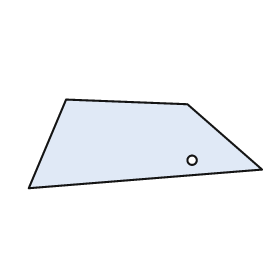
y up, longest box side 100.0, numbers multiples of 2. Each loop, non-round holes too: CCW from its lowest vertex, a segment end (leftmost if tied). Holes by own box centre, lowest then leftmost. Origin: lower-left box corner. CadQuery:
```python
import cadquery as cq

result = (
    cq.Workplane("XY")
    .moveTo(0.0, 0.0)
    .lineTo(100.0, 8.0)
    .lineTo(68.0, 36.0)
    .lineTo(16.0, 38.0)
    .close()
    .moveTo(70.0, 12.0)
    .circle(2.0)
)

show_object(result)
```